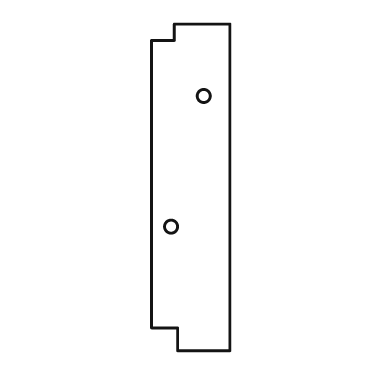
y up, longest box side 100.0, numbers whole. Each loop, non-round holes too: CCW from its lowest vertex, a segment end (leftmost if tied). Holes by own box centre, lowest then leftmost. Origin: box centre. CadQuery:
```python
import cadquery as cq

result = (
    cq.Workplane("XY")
    .moveTo(-4.0, -50.0)
    .lineTo(12.0, -50.0)
    .lineTo(12.0, 50.0)
    .lineTo(-5.0, 50.0)
    .lineTo(-5.0, 45.0)
    .lineTo(-12.0, 45.0)
    .lineTo(-12.0, -43.0)
    .lineTo(-4.0, -43.0)
    .close()
    .moveTo(-6.0, -12.0)
    .circle(2.0)
    .moveTo(4.0, 28.0)
    .circle(2.0)
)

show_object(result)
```